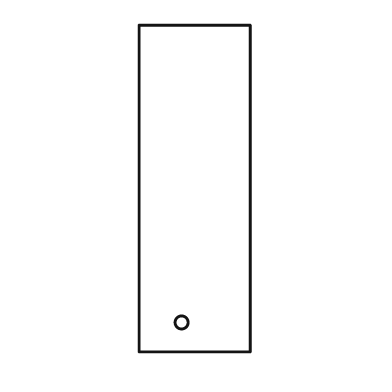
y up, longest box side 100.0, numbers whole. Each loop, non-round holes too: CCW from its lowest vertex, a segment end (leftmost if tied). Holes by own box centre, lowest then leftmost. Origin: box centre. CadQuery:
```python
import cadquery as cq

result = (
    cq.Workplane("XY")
    .moveTo(-17.0, -50.0)
    .lineTo(17.0, -50.0)
    .lineTo(17.0, 50.0)
    .lineTo(-17.0, 50.0)
    .close()
    .moveTo(-4.0, -41.0)
    .circle(2.0)
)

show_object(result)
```